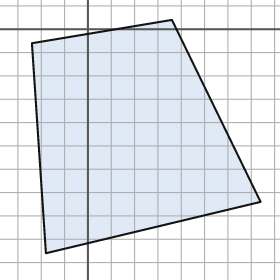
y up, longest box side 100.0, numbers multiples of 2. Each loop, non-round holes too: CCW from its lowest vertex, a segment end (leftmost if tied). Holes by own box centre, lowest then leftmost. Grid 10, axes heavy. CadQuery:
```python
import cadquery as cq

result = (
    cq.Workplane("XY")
    .moveTo(-18.0, -96.0)
    .lineTo(74.0, -74.0)
    .lineTo(36.0, 4.0)
    .lineTo(-24.0, -6.0)
    .close()
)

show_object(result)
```